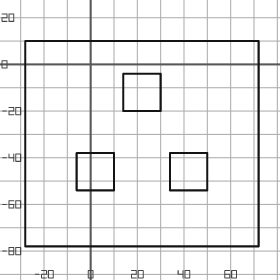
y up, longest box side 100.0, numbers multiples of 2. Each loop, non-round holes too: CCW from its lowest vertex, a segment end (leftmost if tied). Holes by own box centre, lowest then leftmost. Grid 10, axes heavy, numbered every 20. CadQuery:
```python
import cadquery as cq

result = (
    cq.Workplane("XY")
    .moveTo(-28.0, -78.0)
    .lineTo(72.0, -78.0)
    .lineTo(72.0, 10.0)
    .lineTo(-28.0, 10.0)
    .close()
    .moveTo(-6.0, -54.0)
    .lineTo(10.0, -54.0)
    .lineTo(10.0, -38.0)
    .lineTo(-6.0, -38.0)
    .close()
    .moveTo(34.0, -54.0)
    .lineTo(50.0, -54.0)
    .lineTo(50.0, -38.0)
    .lineTo(34.0, -38.0)
    .close()
    .moveTo(14.0, -20.0)
    .lineTo(30.0, -20.0)
    .lineTo(30.0, -4.0)
    .lineTo(14.0, -4.0)
    .close()
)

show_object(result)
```